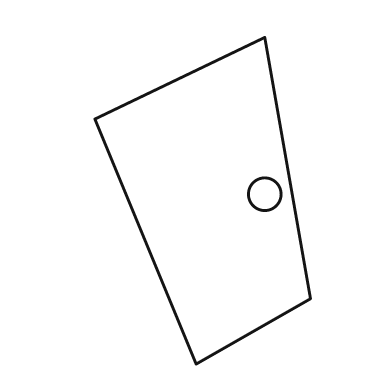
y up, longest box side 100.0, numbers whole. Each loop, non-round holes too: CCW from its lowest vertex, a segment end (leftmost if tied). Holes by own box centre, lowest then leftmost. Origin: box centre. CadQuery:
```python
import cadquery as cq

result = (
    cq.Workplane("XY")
    .moveTo(-2.0, -50.0)
    .lineTo(33.0, -30.0)
    .lineTo(19.0, 50.0)
    .lineTo(-33.0, 25.0)
    .close()
    .moveTo(19.0, 2.0)
    .circle(5.0)
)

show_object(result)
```